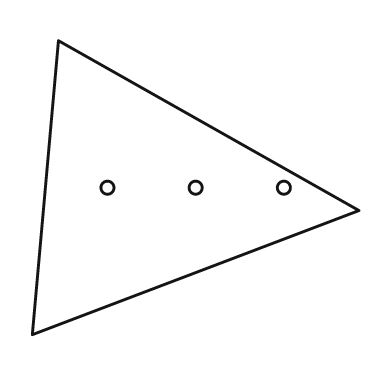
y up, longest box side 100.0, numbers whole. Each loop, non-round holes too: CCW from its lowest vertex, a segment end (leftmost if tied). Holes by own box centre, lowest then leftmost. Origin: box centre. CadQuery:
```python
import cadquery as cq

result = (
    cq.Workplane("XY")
    .moveTo(-50.0, -45.0)
    .lineTo(50.0, -7.0)
    .lineTo(-42.0, 45.0)
    .close()
    .moveTo(-27.0, 0.0)
    .circle(2.0)
    .moveTo(0.0, 0.0)
    .circle(2.0)
    .moveTo(27.0, 0.0)
    .circle(2.0)
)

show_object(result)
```